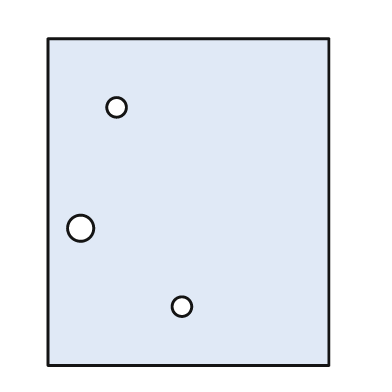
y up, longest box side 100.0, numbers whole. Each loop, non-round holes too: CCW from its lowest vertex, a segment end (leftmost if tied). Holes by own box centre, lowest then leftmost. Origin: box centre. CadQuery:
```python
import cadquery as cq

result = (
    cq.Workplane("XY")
    .moveTo(-43.0, -50.0)
    .lineTo(43.0, -50.0)
    .lineTo(43.0, 50.0)
    .lineTo(-43.0, 50.0)
    .close()
    .moveTo(-2.0, -32.0)
    .circle(3.0)
    .moveTo(-33.0, -8.0)
    .circle(4.0)
    .moveTo(-22.0, 29.0)
    .circle(3.0)
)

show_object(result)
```